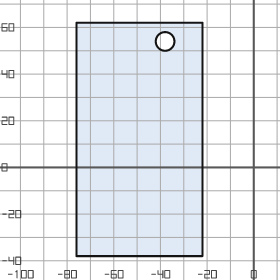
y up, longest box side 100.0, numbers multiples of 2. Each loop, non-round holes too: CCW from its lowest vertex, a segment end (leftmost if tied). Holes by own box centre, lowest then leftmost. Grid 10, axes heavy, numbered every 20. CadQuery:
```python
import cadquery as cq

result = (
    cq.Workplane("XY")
    .moveTo(-76.0, -38.0)
    .lineTo(-22.0, -38.0)
    .lineTo(-22.0, 62.0)
    .lineTo(-76.0, 62.0)
    .close()
    .moveTo(-38.0, 54.0)
    .circle(4.0)
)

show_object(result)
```